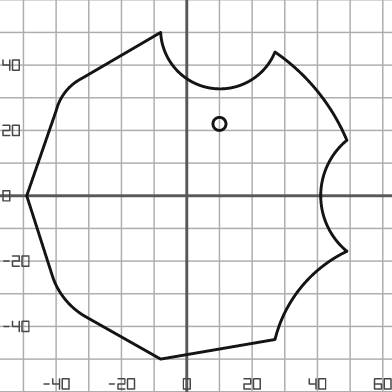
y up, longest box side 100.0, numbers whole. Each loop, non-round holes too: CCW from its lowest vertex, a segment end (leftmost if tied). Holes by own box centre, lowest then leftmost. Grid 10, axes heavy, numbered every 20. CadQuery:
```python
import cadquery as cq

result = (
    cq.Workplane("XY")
    .moveTo(-8.0, -50.0)
    .lineTo(27.0, -44.0)
    .threePointArc((35.0, -28.0), (49.0, -17.0))
    .threePointArc((41.0, 0.0), (49.0, 17.0))
    .threePointArc((40.0, 32.0), (27.0, 44.0))
    .threePointArc((7.0, 33.0), (-8.0, 50.0))
    .lineTo(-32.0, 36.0)
    .threePointArc((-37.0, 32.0), (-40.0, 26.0))
    .lineTo(-49.0, 0.0)
    .lineTo(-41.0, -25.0)
    .threePointArc((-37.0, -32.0), (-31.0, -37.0))
    .close()
    .moveTo(10.0, 22.0)
    .circle(2.0)
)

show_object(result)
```